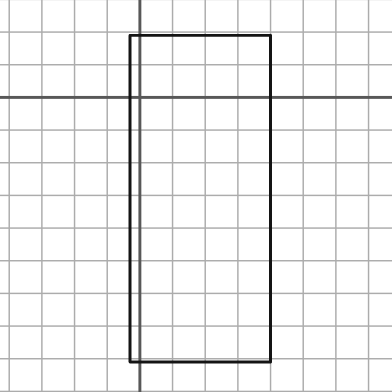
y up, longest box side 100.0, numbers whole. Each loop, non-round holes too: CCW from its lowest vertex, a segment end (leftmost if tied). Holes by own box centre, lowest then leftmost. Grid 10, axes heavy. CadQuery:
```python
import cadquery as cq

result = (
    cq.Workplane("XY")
    .moveTo(-3.0, -81.0)
    .lineTo(40.0, -81.0)
    .lineTo(40.0, 19.0)
    .lineTo(-3.0, 19.0)
    .close()
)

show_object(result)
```